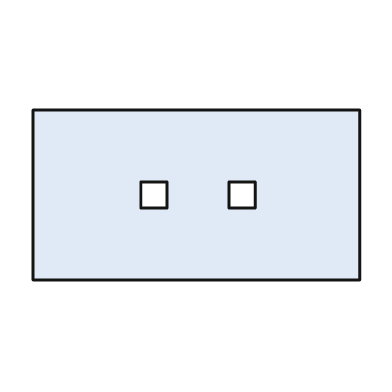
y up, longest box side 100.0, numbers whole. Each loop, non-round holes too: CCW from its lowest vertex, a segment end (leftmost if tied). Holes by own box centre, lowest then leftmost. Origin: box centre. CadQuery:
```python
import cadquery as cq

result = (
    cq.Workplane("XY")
    .moveTo(-50.0, -26.0)
    .lineTo(50.0, -26.0)
    .lineTo(50.0, 26.0)
    .lineTo(-50.0, 26.0)
    .close()
    .moveTo(-17.0, -4.0)
    .lineTo(-9.0, -4.0)
    .lineTo(-9.0, 4.0)
    .lineTo(-17.0, 4.0)
    .close()
    .moveTo(10.0, -4.0)
    .lineTo(18.0, -4.0)
    .lineTo(18.0, 4.0)
    .lineTo(10.0, 4.0)
    .close()
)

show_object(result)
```